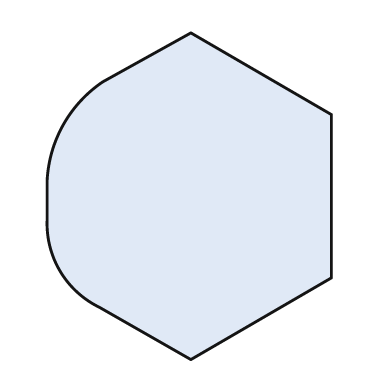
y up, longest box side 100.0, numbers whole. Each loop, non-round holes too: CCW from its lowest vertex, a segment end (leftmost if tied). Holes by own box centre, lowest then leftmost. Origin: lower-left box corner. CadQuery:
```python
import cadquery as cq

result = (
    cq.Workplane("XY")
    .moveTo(44.0, 0.0)
    .lineTo(87.0, 25.0)
    .lineTo(87.0, 75.0)
    .lineTo(44.0, 100.0)
    .lineTo(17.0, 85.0)
    .threePointArc((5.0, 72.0), (0.0, 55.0))
    .lineTo(0.0, 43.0)
    .threePointArc((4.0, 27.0), (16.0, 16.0))
    .close()
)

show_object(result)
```